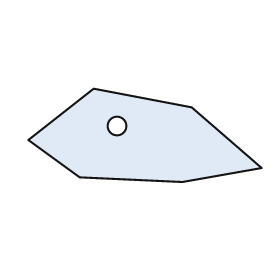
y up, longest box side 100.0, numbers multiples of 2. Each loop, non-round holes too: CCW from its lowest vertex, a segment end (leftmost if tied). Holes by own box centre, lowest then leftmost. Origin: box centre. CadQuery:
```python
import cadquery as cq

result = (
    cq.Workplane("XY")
    .moveTo(16.0, -20.0)
    .lineTo(50.0, -14.0)
    .lineTo(20.0, 12.0)
    .lineTo(-22.0, 20.0)
    .lineTo(-50.0, -2.0)
    .lineTo(-28.0, -18.0)
    .close()
    .moveTo(-12.0, 4.0)
    .circle(4.0)
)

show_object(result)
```